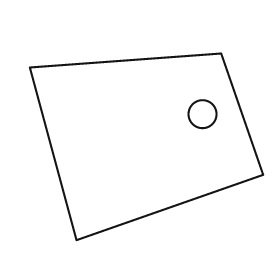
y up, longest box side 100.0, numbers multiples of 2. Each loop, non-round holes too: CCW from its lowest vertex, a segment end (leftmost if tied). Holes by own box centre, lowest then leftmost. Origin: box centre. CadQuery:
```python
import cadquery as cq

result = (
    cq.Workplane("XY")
    .moveTo(-30.0, -40.0)
    .lineTo(50.0, -12.0)
    .lineTo(32.0, 40.0)
    .lineTo(-50.0, 34.0)
    .close()
    .moveTo(24.0, 14.0)
    .circle(6.0)
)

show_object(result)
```